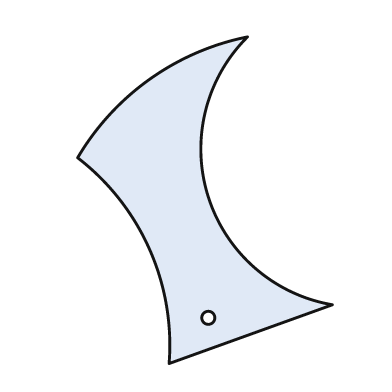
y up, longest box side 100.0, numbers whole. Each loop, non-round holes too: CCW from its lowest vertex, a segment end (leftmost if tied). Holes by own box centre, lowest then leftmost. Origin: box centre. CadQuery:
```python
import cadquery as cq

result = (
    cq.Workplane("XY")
    .moveTo(-11.0, -50.0)
    .lineTo(39.0, -32.0)
    .threePointArc((1.0, 1.0), (13.0, 50.0))
    .threePointArc((-17.0, 37.0), (-39.0, 13.0))
    .threePointArc((-17.0, -15.0), (-11.0, -50.0))
    .close()
    .moveTo(1.0, -36.0)
    .circle(2.0)
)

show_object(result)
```